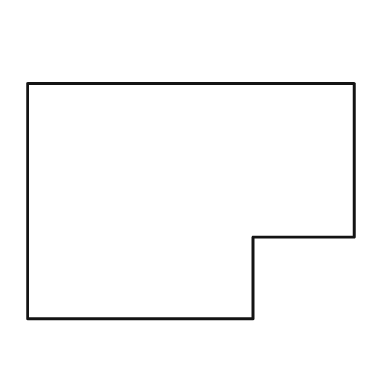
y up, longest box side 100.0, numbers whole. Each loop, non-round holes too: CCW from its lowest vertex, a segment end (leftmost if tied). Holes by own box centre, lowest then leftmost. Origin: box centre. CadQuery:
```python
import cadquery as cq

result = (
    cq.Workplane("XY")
    .moveTo(-50.0, -36.0)
    .lineTo(19.0, -36.0)
    .lineTo(19.0, -11.0)
    .lineTo(50.0, -11.0)
    .lineTo(50.0, 36.0)
    .lineTo(-50.0, 36.0)
    .close()
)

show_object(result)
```